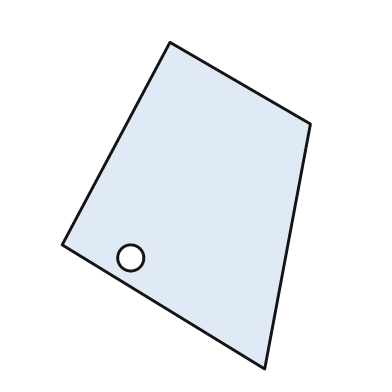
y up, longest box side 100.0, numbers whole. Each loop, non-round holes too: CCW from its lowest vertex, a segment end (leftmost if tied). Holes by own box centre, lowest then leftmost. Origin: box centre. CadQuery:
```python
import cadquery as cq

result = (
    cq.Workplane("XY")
    .moveTo(24.0, -50.0)
    .lineTo(38.0, 25.0)
    .lineTo(-5.0, 50.0)
    .lineTo(-38.0, -12.0)
    .close()
    .moveTo(-17.0, -16.0)
    .circle(4.0)
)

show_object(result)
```